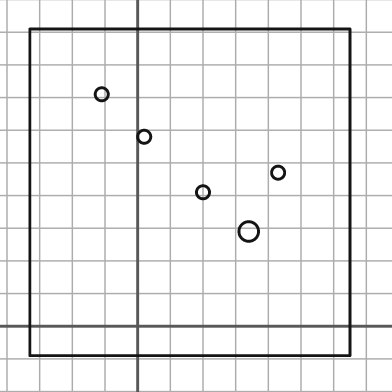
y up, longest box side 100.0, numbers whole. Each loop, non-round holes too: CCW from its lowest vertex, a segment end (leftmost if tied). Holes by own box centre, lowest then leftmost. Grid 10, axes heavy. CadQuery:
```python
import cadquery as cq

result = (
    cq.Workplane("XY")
    .moveTo(-33.0, -9.0)
    .lineTo(65.0, -9.0)
    .lineTo(65.0, 91.0)
    .lineTo(-33.0, 91.0)
    .close()
    .moveTo(34.0, 29.0)
    .circle(3.0)
    .moveTo(20.0, 41.0)
    .circle(2.0)
    .moveTo(43.0, 47.0)
    .circle(2.0)
    .moveTo(2.0, 58.0)
    .circle(2.0)
    .moveTo(-11.0, 71.0)
    .circle(2.0)
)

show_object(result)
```